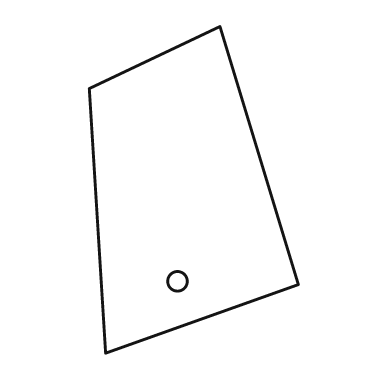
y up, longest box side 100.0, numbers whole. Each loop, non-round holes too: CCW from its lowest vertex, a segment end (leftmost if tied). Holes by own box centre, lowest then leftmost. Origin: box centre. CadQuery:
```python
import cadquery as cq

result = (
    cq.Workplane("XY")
    .moveTo(-27.0, -50.0)
    .lineTo(32.0, -29.0)
    .lineTo(8.0, 50.0)
    .lineTo(-32.0, 31.0)
    .close()
    .moveTo(-5.0, -28.0)
    .circle(3.0)
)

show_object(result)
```